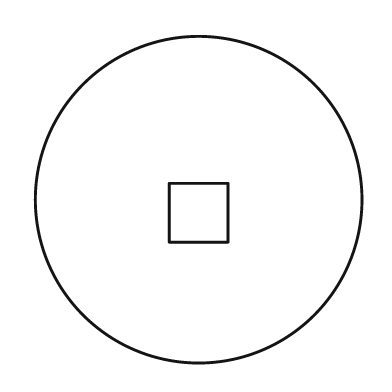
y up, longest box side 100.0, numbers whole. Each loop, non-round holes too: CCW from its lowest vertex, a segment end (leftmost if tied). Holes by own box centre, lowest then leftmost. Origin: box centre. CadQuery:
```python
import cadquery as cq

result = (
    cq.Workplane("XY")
    .moveTo(0.0, 0.0)
    .circle(50.0)
    .moveTo(-9.0, -13.0)
    .lineTo(9.0, -13.0)
    .lineTo(9.0, 5.0)
    .lineTo(-9.0, 5.0)
    .close()
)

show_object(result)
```